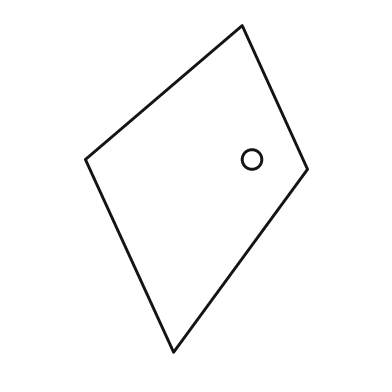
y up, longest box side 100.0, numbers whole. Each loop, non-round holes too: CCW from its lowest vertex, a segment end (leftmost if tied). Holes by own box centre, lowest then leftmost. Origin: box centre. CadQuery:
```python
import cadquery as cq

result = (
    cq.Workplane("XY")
    .moveTo(-7.0, -50.0)
    .lineTo(34.0, 6.0)
    .lineTo(14.0, 50.0)
    .lineTo(-34.0, 9.0)
    .close()
    .moveTo(17.0, 9.0)
    .circle(3.0)
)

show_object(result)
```